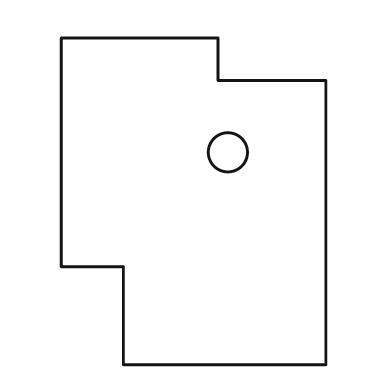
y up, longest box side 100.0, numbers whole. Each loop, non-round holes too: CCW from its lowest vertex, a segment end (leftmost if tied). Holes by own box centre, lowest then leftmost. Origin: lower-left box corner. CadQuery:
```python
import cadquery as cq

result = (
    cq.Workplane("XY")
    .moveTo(19.0, 0.0)
    .lineTo(81.0, 0.0)
    .lineTo(81.0, 87.0)
    .lineTo(48.0, 87.0)
    .lineTo(48.0, 100.0)
    .lineTo(0.0, 100.0)
    .lineTo(0.0, 30.0)
    .lineTo(19.0, 30.0)
    .close()
    .moveTo(51.0, 65.0)
    .circle(6.0)
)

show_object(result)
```